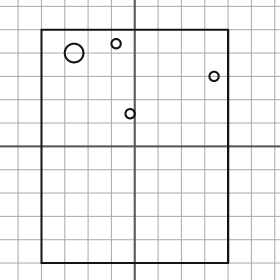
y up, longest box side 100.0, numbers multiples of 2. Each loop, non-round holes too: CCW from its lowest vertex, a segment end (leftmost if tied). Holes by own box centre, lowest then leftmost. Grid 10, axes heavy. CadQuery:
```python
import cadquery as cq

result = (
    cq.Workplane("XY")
    .moveTo(-40.0, -50.0)
    .lineTo(40.0, -50.0)
    .lineTo(40.0, 50.0)
    .lineTo(-40.0, 50.0)
    .close()
    .moveTo(-2.0, 14.0)
    .circle(2.0)
    .moveTo(34.0, 30.0)
    .circle(2.0)
    .moveTo(-26.0, 40.0)
    .circle(4.0)
    .moveTo(-8.0, 44.0)
    .circle(2.0)
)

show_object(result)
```